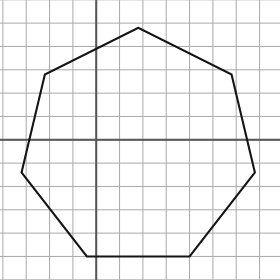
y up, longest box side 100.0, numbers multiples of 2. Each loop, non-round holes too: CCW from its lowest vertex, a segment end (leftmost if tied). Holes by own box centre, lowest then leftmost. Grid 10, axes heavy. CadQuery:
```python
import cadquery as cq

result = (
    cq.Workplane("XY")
    .moveTo(-4.0, -50.0)
    .lineTo(40.0, -50.0)
    .lineTo(68.0, -14.0)
    .lineTo(58.0, 28.0)
    .lineTo(18.0, 48.0)
    .lineTo(-22.0, 28.0)
    .lineTo(-32.0, -14.0)
    .close()
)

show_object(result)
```